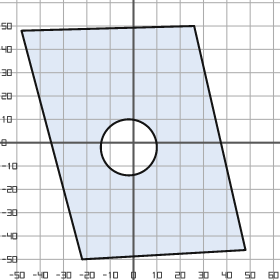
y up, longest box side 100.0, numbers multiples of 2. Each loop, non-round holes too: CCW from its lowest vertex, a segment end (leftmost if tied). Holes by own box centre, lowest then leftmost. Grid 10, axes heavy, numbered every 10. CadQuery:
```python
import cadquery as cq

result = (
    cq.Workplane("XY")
    .moveTo(-22.0, -50.0)
    .lineTo(48.0, -46.0)
    .lineTo(26.0, 50.0)
    .lineTo(-48.0, 48.0)
    .close()
    .moveTo(-2.0, -2.0)
    .circle(12.0)
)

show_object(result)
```